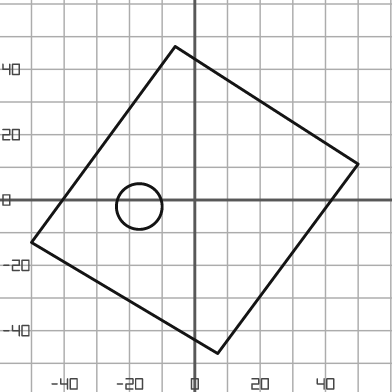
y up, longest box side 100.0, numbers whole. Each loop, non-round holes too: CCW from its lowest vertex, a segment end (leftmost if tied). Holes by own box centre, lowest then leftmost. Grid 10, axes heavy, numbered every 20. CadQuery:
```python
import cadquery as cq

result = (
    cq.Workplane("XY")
    .moveTo(7.0, -47.0)
    .lineTo(50.0, 11.0)
    .lineTo(-6.0, 47.0)
    .lineTo(-50.0, -13.0)
    .close()
    .moveTo(-17.0, -2.0)
    .circle(7.0)
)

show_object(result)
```